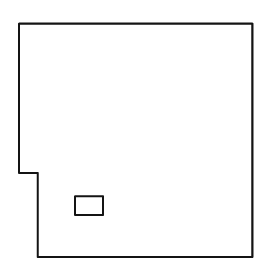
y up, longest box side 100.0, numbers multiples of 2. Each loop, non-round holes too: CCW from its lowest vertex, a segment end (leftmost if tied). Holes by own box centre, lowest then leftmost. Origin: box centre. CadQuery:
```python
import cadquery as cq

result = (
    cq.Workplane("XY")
    .moveTo(-42.0, -50.0)
    .lineTo(50.0, -50.0)
    .lineTo(50.0, 50.0)
    .lineTo(-50.0, 50.0)
    .lineTo(-50.0, -14.0)
    .lineTo(-42.0, -14.0)
    .close()
    .moveTo(-26.0, -32.0)
    .lineTo(-14.0, -32.0)
    .lineTo(-14.0, -24.0)
    .lineTo(-26.0, -24.0)
    .close()
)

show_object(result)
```